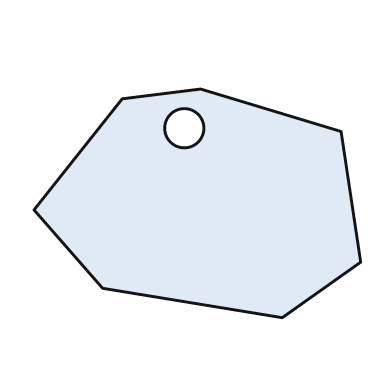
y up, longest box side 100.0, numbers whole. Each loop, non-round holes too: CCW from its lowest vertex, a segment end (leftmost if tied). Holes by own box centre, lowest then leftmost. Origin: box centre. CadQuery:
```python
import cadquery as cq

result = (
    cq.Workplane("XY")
    .moveTo(26.0, -35.0)
    .lineTo(50.0, -18.0)
    .lineTo(44.0, 22.0)
    .lineTo(1.0, 35.0)
    .lineTo(-23.0, 32.0)
    .lineTo(-50.0, -2.0)
    .lineTo(-29.0, -26.0)
    .close()
    .moveTo(-4.0, 23.0)
    .circle(6.0)
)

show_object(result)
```